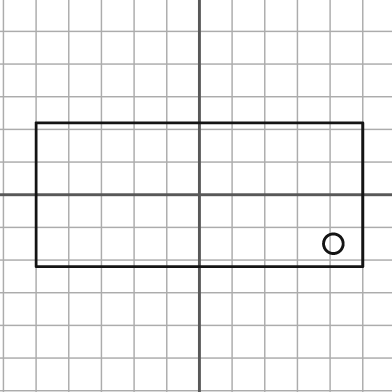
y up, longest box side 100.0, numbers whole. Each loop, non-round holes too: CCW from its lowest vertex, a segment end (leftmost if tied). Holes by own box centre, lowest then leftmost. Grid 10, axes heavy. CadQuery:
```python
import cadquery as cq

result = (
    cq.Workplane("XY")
    .moveTo(-50.0, -22.0)
    .lineTo(50.0, -22.0)
    .lineTo(50.0, 22.0)
    .lineTo(-50.0, 22.0)
    .close()
    .moveTo(41.0, -15.0)
    .circle(3.0)
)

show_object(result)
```